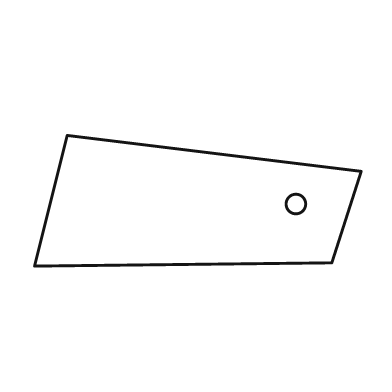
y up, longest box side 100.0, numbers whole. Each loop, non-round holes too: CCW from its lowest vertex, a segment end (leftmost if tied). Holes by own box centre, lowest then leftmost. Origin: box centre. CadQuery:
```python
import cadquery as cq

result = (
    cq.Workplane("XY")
    .moveTo(-50.0, -20.0)
    .lineTo(41.0, -19.0)
    .lineTo(50.0, 9.0)
    .lineTo(-40.0, 20.0)
    .close()
    .moveTo(30.0, -1.0)
    .circle(3.0)
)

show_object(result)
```